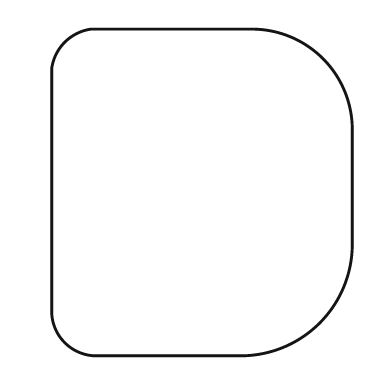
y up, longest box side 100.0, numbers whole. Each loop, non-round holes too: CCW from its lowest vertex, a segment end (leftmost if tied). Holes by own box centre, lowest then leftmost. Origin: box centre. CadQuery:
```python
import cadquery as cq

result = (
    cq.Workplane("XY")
    .moveTo(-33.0, -50.0)
    .lineTo(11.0, -50.0)
    .threePointArc((36.0, -40.0), (46.0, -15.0))
    .lineTo(46.0, 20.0)
    .threePointArc((37.0, 41.0), (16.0, 50.0))
    .lineTo(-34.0, 50.0)
    .threePointArc((-42.0, 46.0), (-46.0, 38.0))
    .lineTo(-46.0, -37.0)
    .threePointArc((-42.0, -46.0), (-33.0, -50.0))
    .close()
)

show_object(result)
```